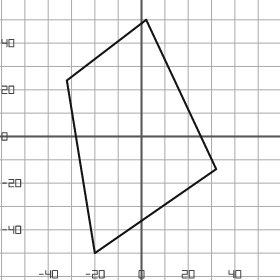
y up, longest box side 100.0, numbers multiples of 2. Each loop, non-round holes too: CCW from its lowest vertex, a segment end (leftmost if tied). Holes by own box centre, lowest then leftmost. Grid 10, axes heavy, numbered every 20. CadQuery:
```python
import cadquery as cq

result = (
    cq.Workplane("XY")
    .moveTo(-20.0, -50.0)
    .lineTo(32.0, -14.0)
    .lineTo(2.0, 50.0)
    .lineTo(-32.0, 24.0)
    .close()
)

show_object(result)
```